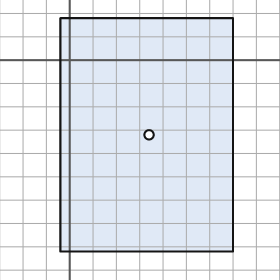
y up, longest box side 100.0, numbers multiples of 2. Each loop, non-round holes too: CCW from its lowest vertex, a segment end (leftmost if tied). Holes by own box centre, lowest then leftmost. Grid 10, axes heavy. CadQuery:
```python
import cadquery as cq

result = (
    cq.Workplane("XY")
    .moveTo(-4.0, -82.0)
    .lineTo(70.0, -82.0)
    .lineTo(70.0, 18.0)
    .lineTo(-4.0, 18.0)
    .close()
    .moveTo(34.0, -32.0)
    .circle(2.0)
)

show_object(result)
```